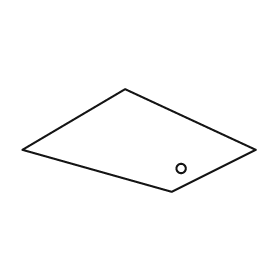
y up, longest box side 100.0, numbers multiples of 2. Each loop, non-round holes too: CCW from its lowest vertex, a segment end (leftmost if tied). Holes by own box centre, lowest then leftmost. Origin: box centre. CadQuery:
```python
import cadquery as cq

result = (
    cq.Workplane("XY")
    .moveTo(14.0, -22.0)
    .lineTo(50.0, -4.0)
    .lineTo(-6.0, 22.0)
    .lineTo(-50.0, -4.0)
    .close()
    .moveTo(18.0, -12.0)
    .circle(2.0)
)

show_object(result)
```